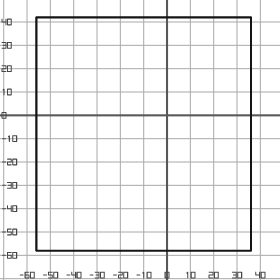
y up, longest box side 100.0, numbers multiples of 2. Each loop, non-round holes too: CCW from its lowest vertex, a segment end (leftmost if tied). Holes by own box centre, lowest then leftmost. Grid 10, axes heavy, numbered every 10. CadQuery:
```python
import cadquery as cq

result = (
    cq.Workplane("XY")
    .moveTo(-56.0, -58.0)
    .lineTo(36.0, -58.0)
    .lineTo(36.0, 42.0)
    .lineTo(-56.0, 42.0)
    .close()
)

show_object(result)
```